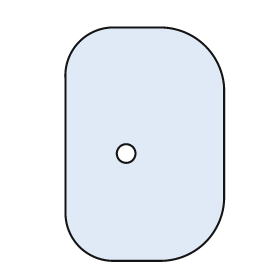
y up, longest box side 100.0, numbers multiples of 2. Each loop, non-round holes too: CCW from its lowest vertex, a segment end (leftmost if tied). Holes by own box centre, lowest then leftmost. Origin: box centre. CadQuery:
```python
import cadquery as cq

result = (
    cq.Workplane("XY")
    .moveTo(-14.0, -50.0)
    .lineTo(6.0, -50.0)
    .threePointArc((26.0, -42.0), (34.0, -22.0))
    .lineTo(34.0, 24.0)
    .threePointArc((26.0, 42.0), (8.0, 50.0))
    .lineTo(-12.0, 50.0)
    .threePointArc((-28.0, 44.0), (-34.0, 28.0))
    .lineTo(-34.0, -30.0)
    .threePointArc((-28.0, -44.0), (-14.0, -50.0))
    .close()
    .moveTo(-8.0, -4.0)
    .circle(4.0)
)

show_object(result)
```